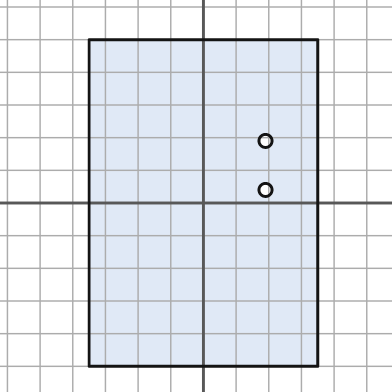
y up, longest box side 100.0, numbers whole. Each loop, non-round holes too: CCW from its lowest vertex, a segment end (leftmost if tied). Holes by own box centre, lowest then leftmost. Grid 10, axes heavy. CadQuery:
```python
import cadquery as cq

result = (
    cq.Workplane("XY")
    .moveTo(-35.0, -50.0)
    .lineTo(35.0, -50.0)
    .lineTo(35.0, 50.0)
    .lineTo(-35.0, 50.0)
    .close()
    .moveTo(19.0, 4.0)
    .circle(2.0)
    .moveTo(19.0, 19.0)
    .circle(2.0)
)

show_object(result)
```